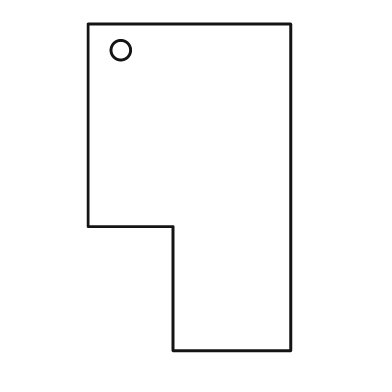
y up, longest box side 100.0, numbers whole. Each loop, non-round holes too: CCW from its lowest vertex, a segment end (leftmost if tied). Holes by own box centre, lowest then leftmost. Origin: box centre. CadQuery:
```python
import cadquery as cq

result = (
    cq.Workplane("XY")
    .moveTo(-5.0, -50.0)
    .lineTo(31.0, -50.0)
    .lineTo(31.0, 50.0)
    .lineTo(-31.0, 50.0)
    .lineTo(-31.0, -12.0)
    .lineTo(-5.0, -12.0)
    .close()
    .moveTo(-21.0, 42.0)
    .circle(3.0)
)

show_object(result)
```